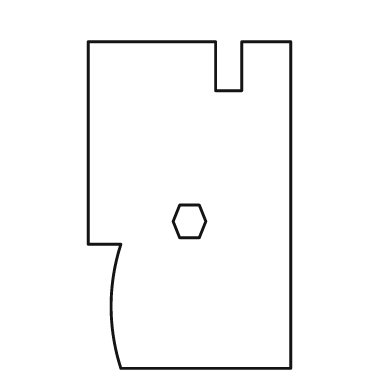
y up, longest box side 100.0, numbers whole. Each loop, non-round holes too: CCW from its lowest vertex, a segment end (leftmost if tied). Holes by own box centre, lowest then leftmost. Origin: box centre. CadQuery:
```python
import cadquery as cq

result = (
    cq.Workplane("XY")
    .moveTo(-21.0, -50.0)
    .lineTo(31.0, -50.0)
    .lineTo(31.0, 50.0)
    .lineTo(16.0, 50.0)
    .lineTo(16.0, 35.0)
    .lineTo(8.0, 35.0)
    .lineTo(8.0, 50.0)
    .lineTo(-31.0, 50.0)
    .lineTo(-31.0, -12.0)
    .lineTo(-21.0, -12.0)
    .threePointArc((-24.0, -31.0), (-21.0, -50.0))
    .close()
    .moveTo(-3.0, -10.0)
    .lineTo(3.0, -10.0)
    .lineTo(5.0, -5.0)
    .lineTo(3.0, 0.0)
    .lineTo(-3.0, 0.0)
    .lineTo(-5.0, -5.0)
    .close()
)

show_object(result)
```